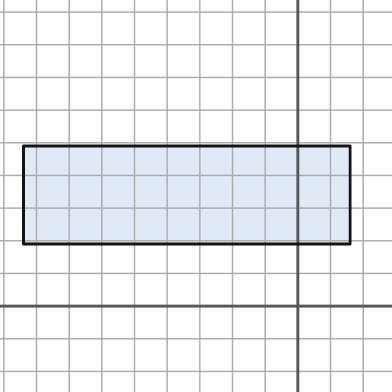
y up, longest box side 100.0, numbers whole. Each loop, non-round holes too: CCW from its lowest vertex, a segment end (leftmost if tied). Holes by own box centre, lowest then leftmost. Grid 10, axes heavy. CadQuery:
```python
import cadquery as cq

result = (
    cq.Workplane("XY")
    .moveTo(-84.0, 19.0)
    .lineTo(16.0, 19.0)
    .lineTo(16.0, 49.0)
    .lineTo(-84.0, 49.0)
    .close()
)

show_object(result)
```